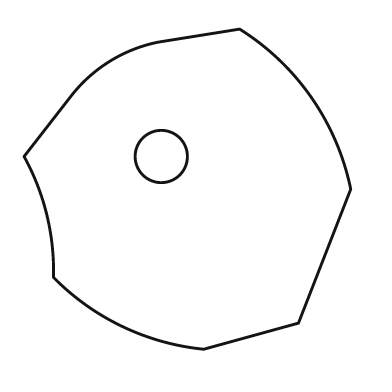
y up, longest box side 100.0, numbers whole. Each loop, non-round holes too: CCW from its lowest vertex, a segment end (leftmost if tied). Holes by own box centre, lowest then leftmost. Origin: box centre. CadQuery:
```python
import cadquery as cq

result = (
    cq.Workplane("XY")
    .moveTo(5.0, -49.0)
    .lineTo(34.0, -41.0)
    .lineTo(50.0, 0.0)
    .threePointArc((38.0, 28.0), (16.0, 49.0))
    .lineTo(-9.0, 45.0)
    .threePointArc((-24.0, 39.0), (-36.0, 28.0))
    .lineTo(-50.0, 10.0)
    .threePointArc((-43.0, -8.0), (-41.0, -27.0))
    .threePointArc((-20.0, -42.0), (5.0, -49.0))
    .close()
    .moveTo(-8.0, 10.0)
    .circle(8.0)
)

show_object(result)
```